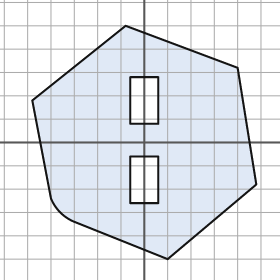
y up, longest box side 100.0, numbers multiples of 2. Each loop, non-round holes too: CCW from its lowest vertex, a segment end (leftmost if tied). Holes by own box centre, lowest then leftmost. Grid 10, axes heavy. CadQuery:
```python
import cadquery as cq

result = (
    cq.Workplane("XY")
    .moveTo(10.0, -50.0)
    .lineTo(48.0, -18.0)
    .lineTo(40.0, 32.0)
    .lineTo(-8.0, 50.0)
    .lineTo(-48.0, 18.0)
    .lineTo(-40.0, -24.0)
    .threePointArc((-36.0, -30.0), (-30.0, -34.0))
    .close()
    .moveTo(-6.0, -26.0)
    .lineTo(6.0, -26.0)
    .lineTo(6.0, -6.0)
    .lineTo(-6.0, -6.0)
    .close()
    .moveTo(-6.0, 8.0)
    .lineTo(6.0, 8.0)
    .lineTo(6.0, 28.0)
    .lineTo(-6.0, 28.0)
    .close()
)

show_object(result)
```